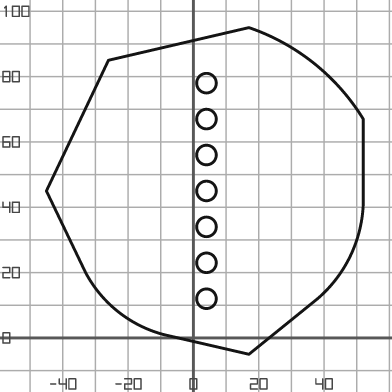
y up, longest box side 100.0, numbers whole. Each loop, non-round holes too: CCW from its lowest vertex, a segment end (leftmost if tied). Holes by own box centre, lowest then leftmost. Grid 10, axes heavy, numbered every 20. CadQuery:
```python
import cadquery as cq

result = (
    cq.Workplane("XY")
    .moveTo(17.0, -5.0)
    .lineTo(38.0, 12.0)
    .threePointArc((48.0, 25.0), (52.0, 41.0))
    .lineTo(52.0, 67.0)
    .threePointArc((37.0, 84.0), (17.0, 95.0))
    .lineTo(-26.0, 85.0)
    .lineTo(-45.0, 45.0)
    .lineTo(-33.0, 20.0)
    .threePointArc((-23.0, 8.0), (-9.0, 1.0))
    .close()
    .moveTo(4.0, 12.0)
    .circle(3.0)
    .moveTo(4.0, 23.0)
    .circle(3.0)
    .moveTo(4.0, 34.0)
    .circle(3.0)
    .moveTo(4.0, 45.0)
    .circle(3.0)
    .moveTo(4.0, 56.0)
    .circle(3.0)
    .moveTo(4.0, 67.0)
    .circle(3.0)
    .moveTo(4.0, 78.0)
    .circle(3.0)
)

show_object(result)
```